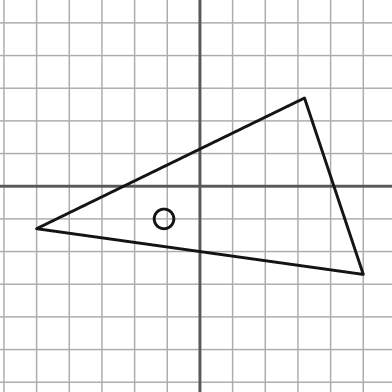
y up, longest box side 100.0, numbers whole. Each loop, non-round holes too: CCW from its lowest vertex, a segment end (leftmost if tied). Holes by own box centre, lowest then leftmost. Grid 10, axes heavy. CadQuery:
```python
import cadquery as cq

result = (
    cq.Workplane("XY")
    .moveTo(50.0, -27.0)
    .lineTo(32.0, 27.0)
    .lineTo(-50.0, -13.0)
    .close()
    .moveTo(-11.0, -10.0)
    .circle(3.0)
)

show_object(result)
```